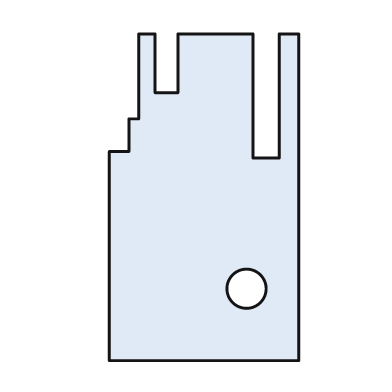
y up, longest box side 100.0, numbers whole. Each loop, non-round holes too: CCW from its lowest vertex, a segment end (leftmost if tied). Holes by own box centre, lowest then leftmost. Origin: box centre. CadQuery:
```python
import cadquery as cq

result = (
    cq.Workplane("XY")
    .moveTo(-29.0, -50.0)
    .lineTo(29.0, -50.0)
    .lineTo(29.0, 50.0)
    .lineTo(23.0, 50.0)
    .lineTo(23.0, 12.0)
    .lineTo(15.0, 12.0)
    .lineTo(15.0, 50.0)
    .lineTo(-8.0, 50.0)
    .lineTo(-8.0, 32.0)
    .lineTo(-15.0, 32.0)
    .lineTo(-15.0, 50.0)
    .lineTo(-20.0, 50.0)
    .lineTo(-20.0, 24.0)
    .lineTo(-23.0, 24.0)
    .lineTo(-23.0, 14.0)
    .lineTo(-29.0, 14.0)
    .close()
    .moveTo(13.0, -28.0)
    .circle(6.0)
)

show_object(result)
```